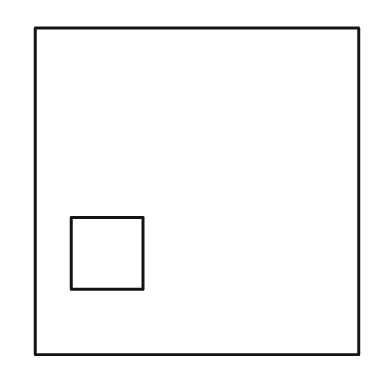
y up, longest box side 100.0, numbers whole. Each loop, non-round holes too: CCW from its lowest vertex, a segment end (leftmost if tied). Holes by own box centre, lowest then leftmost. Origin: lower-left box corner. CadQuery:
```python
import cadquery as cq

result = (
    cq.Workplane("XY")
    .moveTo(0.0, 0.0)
    .lineTo(99.0, 0.0)
    .lineTo(99.0, 100.0)
    .lineTo(0.0, 100.0)
    .close()
    .moveTo(11.0, 20.0)
    .lineTo(33.0, 20.0)
    .lineTo(33.0, 42.0)
    .lineTo(11.0, 42.0)
    .close()
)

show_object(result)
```